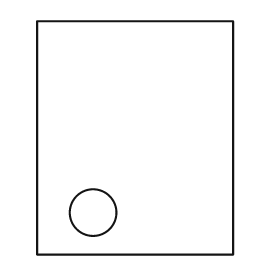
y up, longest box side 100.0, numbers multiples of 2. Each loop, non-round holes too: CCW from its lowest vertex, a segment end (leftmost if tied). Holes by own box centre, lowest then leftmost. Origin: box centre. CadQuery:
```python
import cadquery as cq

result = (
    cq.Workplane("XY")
    .moveTo(-42.0, -50.0)
    .lineTo(42.0, -50.0)
    .lineTo(42.0, 50.0)
    .lineTo(-42.0, 50.0)
    .close()
    .moveTo(-18.0, -32.0)
    .circle(10.0)
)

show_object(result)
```